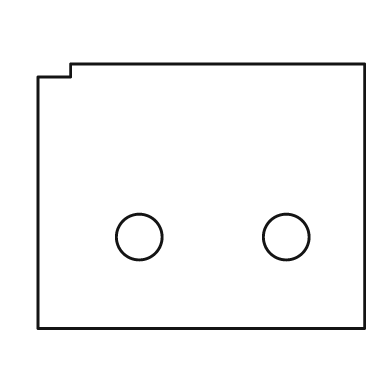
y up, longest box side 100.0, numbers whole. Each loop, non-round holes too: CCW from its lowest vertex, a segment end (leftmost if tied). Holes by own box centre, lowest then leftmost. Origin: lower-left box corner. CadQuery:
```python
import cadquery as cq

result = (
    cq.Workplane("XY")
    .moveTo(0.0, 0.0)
    .lineTo(100.0, 0.0)
    .lineTo(100.0, 81.0)
    .lineTo(10.0, 81.0)
    .lineTo(10.0, 77.0)
    .lineTo(0.0, 77.0)
    .close()
    .moveTo(31.0, 28.0)
    .circle(7.0)
    .moveTo(76.0, 28.0)
    .circle(7.0)
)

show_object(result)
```